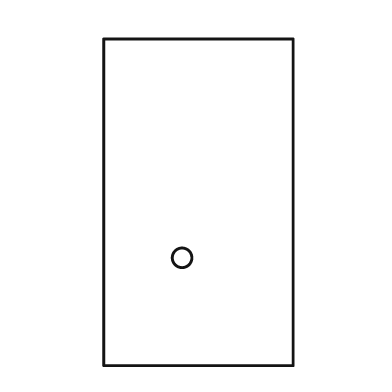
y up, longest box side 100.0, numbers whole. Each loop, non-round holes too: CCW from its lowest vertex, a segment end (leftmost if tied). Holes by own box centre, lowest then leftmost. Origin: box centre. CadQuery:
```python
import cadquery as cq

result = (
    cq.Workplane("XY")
    .moveTo(-29.0, -50.0)
    .lineTo(29.0, -50.0)
    .lineTo(29.0, 50.0)
    .lineTo(-29.0, 50.0)
    .close()
    .moveTo(-5.0, -17.0)
    .circle(3.0)
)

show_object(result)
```